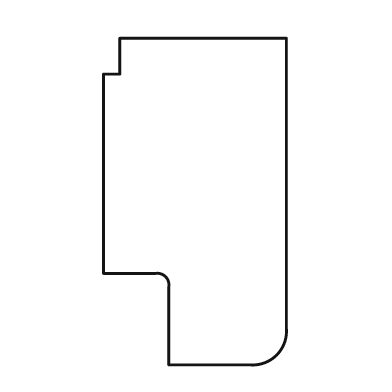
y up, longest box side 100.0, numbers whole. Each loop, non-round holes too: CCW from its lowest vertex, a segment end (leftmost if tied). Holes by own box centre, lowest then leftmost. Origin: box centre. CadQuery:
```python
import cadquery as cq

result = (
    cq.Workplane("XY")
    .moveTo(-8.0, -50.0)
    .lineTo(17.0, -50.0)
    .threePointArc((25.0, -47.0), (28.0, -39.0))
    .lineTo(28.0, 50.0)
    .lineTo(-23.0, 50.0)
    .lineTo(-23.0, 39.0)
    .lineTo(-28.0, 39.0)
    .lineTo(-28.0, -22.0)
    .lineTo(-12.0, -22.0)
    .threePointArc((-9.0, -23.0), (-8.0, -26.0))
    .close()
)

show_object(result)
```